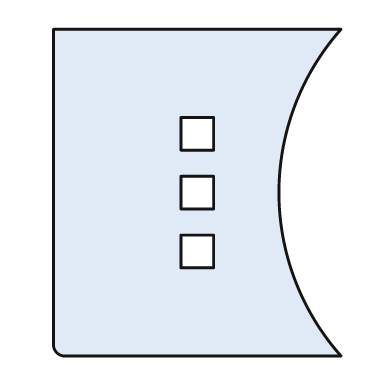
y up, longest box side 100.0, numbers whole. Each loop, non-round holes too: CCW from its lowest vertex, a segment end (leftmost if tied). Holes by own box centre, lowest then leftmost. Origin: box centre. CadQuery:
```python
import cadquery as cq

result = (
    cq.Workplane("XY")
    .moveTo(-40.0, -50.0)
    .lineTo(44.0, -50.0)
    .threePointArc((25.0, 0.0), (44.0, 50.0))
    .lineTo(-44.0, 50.0)
    .lineTo(-44.0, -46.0)
    .threePointArc((-43.0, -49.0), (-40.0, -50.0))
    .close()
    .moveTo(-5.0, -23.0)
    .lineTo(5.0, -23.0)
    .lineTo(5.0, -13.0)
    .lineTo(-5.0, -13.0)
    .close()
    .moveTo(-5.0, -5.0)
    .lineTo(5.0, -5.0)
    .lineTo(5.0, 5.0)
    .lineTo(-5.0, 5.0)
    .close()
    .moveTo(-5.0, 13.0)
    .lineTo(5.0, 13.0)
    .lineTo(5.0, 23.0)
    .lineTo(-5.0, 23.0)
    .close()
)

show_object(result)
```